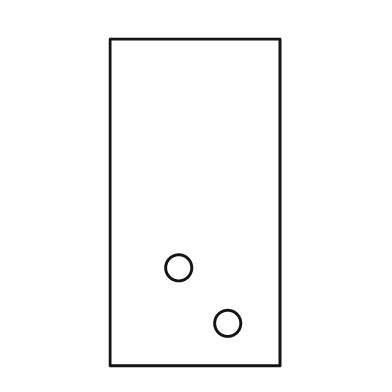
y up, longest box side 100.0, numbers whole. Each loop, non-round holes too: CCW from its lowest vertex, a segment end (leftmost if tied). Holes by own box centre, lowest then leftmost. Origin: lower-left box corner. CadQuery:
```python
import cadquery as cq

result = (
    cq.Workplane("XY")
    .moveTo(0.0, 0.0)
    .lineTo(52.0, 0.0)
    .lineTo(52.0, 100.0)
    .lineTo(0.0, 100.0)
    .close()
    .moveTo(36.0, 13.0)
    .circle(4.0)
    .moveTo(21.0, 30.0)
    .circle(4.0)
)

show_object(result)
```